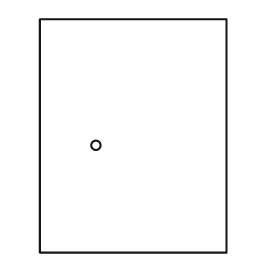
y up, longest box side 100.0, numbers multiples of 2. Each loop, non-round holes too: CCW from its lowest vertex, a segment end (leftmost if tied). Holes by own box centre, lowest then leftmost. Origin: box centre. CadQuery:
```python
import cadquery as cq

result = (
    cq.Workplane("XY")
    .moveTo(-40.0, -50.0)
    .lineTo(40.0, -50.0)
    .lineTo(40.0, 50.0)
    .lineTo(-40.0, 50.0)
    .close()
    .moveTo(-16.0, -4.0)
    .circle(2.0)
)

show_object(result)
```